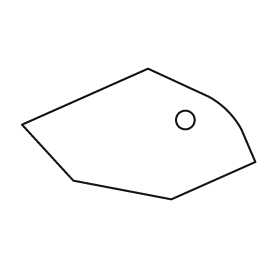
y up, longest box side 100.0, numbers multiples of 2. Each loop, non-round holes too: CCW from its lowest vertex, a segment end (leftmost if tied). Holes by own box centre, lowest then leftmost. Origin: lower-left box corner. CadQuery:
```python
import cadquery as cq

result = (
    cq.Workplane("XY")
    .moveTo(64.0, 0.0)
    .lineTo(100.0, 16.0)
    .lineTo(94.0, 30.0)
    .threePointArc((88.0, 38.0), (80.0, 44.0))
    .lineTo(54.0, 56.0)
    .lineTo(0.0, 32.0)
    .lineTo(22.0, 8.0)
    .close()
    .moveTo(70.0, 34.0)
    .circle(4.0)
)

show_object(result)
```